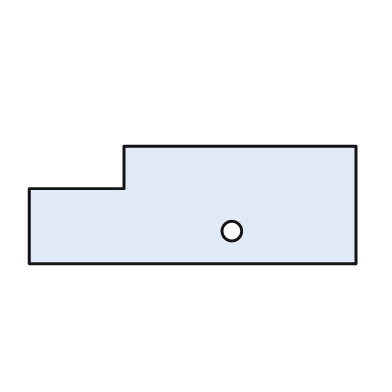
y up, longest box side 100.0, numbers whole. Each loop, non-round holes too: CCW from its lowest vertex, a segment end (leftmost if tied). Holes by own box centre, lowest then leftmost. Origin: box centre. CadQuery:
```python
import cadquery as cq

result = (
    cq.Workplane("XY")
    .moveTo(-50.0, -18.0)
    .lineTo(50.0, -18.0)
    .lineTo(50.0, 18.0)
    .lineTo(-21.0, 18.0)
    .lineTo(-21.0, 5.0)
    .lineTo(-50.0, 5.0)
    .close()
    .moveTo(12.0, -8.0)
    .circle(3.0)
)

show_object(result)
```